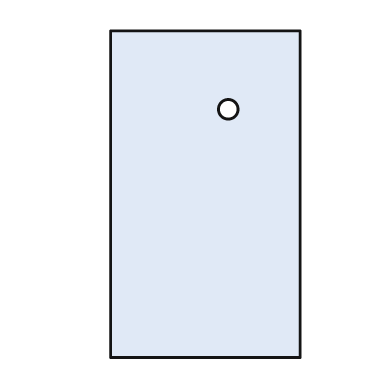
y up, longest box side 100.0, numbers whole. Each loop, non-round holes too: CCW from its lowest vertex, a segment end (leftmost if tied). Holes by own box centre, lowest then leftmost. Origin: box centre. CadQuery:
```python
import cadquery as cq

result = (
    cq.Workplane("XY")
    .moveTo(-29.0, -50.0)
    .lineTo(29.0, -50.0)
    .lineTo(29.0, 50.0)
    .lineTo(-29.0, 50.0)
    .close()
    .moveTo(7.0, 26.0)
    .circle(3.0)
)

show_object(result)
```